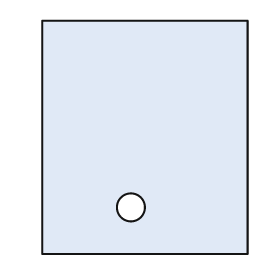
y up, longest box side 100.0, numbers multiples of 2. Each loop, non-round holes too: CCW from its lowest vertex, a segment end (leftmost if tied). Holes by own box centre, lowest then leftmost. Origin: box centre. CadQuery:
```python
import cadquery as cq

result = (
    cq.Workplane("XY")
    .moveTo(-44.0, -50.0)
    .lineTo(44.0, -50.0)
    .lineTo(44.0, 50.0)
    .lineTo(-44.0, 50.0)
    .close()
    .moveTo(-6.0, -30.0)
    .circle(6.0)
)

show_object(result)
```